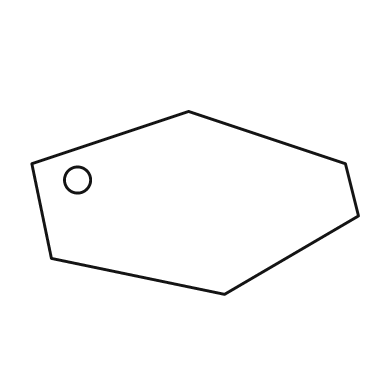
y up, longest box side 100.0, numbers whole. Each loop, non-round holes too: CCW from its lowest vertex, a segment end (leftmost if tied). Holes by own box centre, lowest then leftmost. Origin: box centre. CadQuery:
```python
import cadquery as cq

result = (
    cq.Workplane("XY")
    .moveTo(9.0, -28.0)
    .lineTo(50.0, -4.0)
    .lineTo(46.0, 12.0)
    .lineTo(-2.0, 28.0)
    .lineTo(-50.0, 12.0)
    .lineTo(-44.0, -17.0)
    .close()
    .moveTo(-36.0, 7.0)
    .circle(4.0)
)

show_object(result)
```